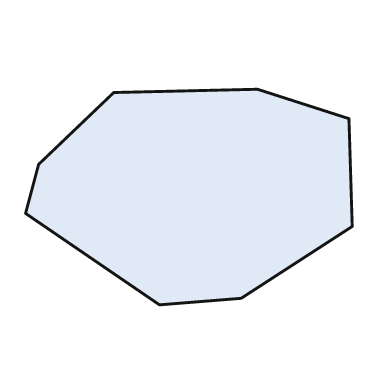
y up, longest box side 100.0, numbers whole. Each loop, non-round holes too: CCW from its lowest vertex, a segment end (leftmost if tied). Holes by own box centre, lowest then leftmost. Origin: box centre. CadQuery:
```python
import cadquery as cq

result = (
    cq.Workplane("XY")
    .moveTo(-9.0, -33.0)
    .lineTo(16.0, -31.0)
    .lineTo(50.0, -9.0)
    .lineTo(49.0, 24.0)
    .lineTo(21.0, 33.0)
    .lineTo(-23.0, 32.0)
    .lineTo(-46.0, 10.0)
    .lineTo(-50.0, -5.0)
    .close()
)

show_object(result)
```